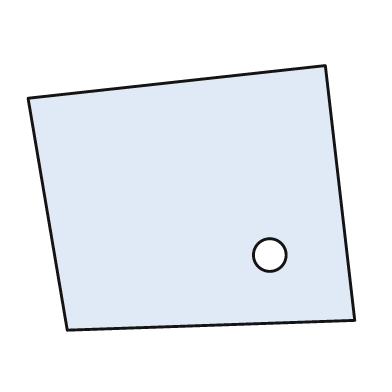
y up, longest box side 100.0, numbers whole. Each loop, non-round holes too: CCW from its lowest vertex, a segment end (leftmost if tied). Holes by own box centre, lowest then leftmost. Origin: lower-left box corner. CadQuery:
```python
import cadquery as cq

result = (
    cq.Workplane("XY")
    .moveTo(12.0, 0.0)
    .lineTo(100.0, 3.0)
    .lineTo(91.0, 81.0)
    .lineTo(0.0, 71.0)
    .close()
    .moveTo(74.0, 23.0)
    .circle(5.0)
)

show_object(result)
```